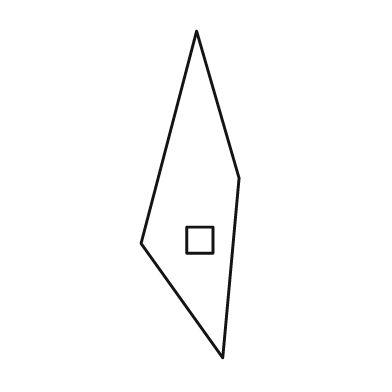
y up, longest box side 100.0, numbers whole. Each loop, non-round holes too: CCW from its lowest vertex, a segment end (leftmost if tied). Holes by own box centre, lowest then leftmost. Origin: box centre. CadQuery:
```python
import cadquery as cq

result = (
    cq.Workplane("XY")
    .moveTo(10.0, -50.0)
    .lineTo(15.0, 5.0)
    .lineTo(2.0, 50.0)
    .lineTo(-15.0, -15.0)
    .close()
    .moveTo(-1.0, -18.0)
    .lineTo(7.0, -18.0)
    .lineTo(7.0, -10.0)
    .lineTo(-1.0, -10.0)
    .close()
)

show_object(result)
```